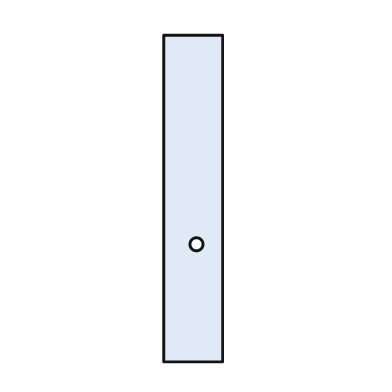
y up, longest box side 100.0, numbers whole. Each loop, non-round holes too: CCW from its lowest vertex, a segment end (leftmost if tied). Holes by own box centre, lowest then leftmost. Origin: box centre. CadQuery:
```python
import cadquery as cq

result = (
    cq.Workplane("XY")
    .moveTo(-9.0, -50.0)
    .lineTo(9.0, -50.0)
    .lineTo(9.0, 50.0)
    .lineTo(-9.0, 50.0)
    .close()
    .moveTo(1.0, -14.0)
    .circle(2.0)
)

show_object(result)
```